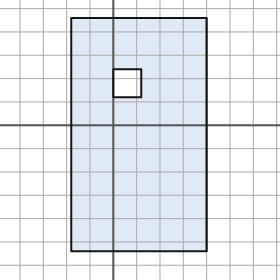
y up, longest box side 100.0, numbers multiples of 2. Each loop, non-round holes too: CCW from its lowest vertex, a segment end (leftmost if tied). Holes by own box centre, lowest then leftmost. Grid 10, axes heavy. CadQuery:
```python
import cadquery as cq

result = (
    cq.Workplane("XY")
    .moveTo(-18.0, -54.0)
    .lineTo(40.0, -54.0)
    .lineTo(40.0, 46.0)
    .lineTo(-18.0, 46.0)
    .close()
    .moveTo(0.0, 12.0)
    .lineTo(12.0, 12.0)
    .lineTo(12.0, 24.0)
    .lineTo(0.0, 24.0)
    .close()
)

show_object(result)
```